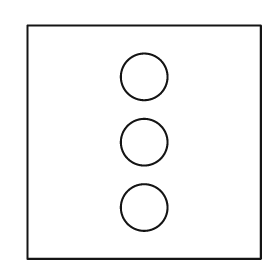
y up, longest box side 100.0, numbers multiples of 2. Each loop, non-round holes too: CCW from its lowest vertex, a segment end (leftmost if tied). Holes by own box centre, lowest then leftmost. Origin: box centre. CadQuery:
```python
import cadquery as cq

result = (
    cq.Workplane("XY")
    .moveTo(-50.0, -50.0)
    .lineTo(50.0, -50.0)
    .lineTo(50.0, 50.0)
    .lineTo(-50.0, 50.0)
    .close()
    .moveTo(0.0, -28.0)
    .circle(10.0)
    .moveTo(0.0, 0.0)
    .circle(10.0)
    .moveTo(0.0, 28.0)
    .circle(10.0)
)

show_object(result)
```